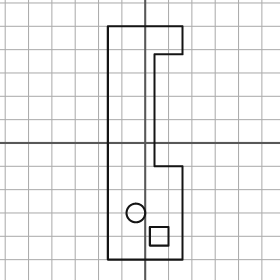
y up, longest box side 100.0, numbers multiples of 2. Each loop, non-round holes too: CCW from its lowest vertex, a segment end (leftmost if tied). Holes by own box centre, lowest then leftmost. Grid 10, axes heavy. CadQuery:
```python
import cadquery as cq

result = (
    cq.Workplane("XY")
    .moveTo(-16.0, -50.0)
    .lineTo(16.0, -50.0)
    .lineTo(16.0, -10.0)
    .lineTo(4.0, -10.0)
    .lineTo(4.0, 38.0)
    .lineTo(16.0, 38.0)
    .lineTo(16.0, 50.0)
    .lineTo(-16.0, 50.0)
    .close()
    .moveTo(2.0, -44.0)
    .lineTo(10.0, -44.0)
    .lineTo(10.0, -36.0)
    .lineTo(2.0, -36.0)
    .close()
    .moveTo(-4.0, -30.0)
    .circle(4.0)
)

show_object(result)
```